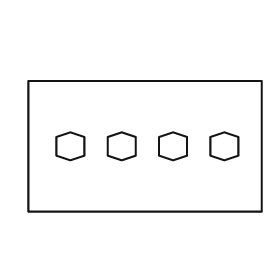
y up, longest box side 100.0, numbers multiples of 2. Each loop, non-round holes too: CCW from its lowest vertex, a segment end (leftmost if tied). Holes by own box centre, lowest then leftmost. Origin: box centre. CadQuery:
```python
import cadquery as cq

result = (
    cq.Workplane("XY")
    .moveTo(-50.0, -28.0)
    .lineTo(50.0, -28.0)
    .lineTo(50.0, 28.0)
    .lineTo(-50.0, 28.0)
    .close()
    .moveTo(-32.0, -6.0)
    .lineTo(-26.0, -4.0)
    .lineTo(-26.0, 4.0)
    .lineTo(-32.0, 6.0)
    .lineTo(-38.0, 4.0)
    .lineTo(-38.0, -4.0)
    .close()
    .moveTo(-10.0, -6.0)
    .lineTo(-4.0, -4.0)
    .lineTo(-4.0, 4.0)
    .lineTo(-10.0, 6.0)
    .lineTo(-16.0, 4.0)
    .lineTo(-16.0, -4.0)
    .close()
    .moveTo(12.0, -6.0)
    .lineTo(18.0, -4.0)
    .lineTo(18.0, 4.0)
    .lineTo(12.0, 6.0)
    .lineTo(6.0, 4.0)
    .lineTo(6.0, -4.0)
    .close()
    .moveTo(34.0, -6.0)
    .lineTo(40.0, -4.0)
    .lineTo(40.0, 4.0)
    .lineTo(34.0, 6.0)
    .lineTo(28.0, 4.0)
    .lineTo(28.0, -4.0)
    .close()
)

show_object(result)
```